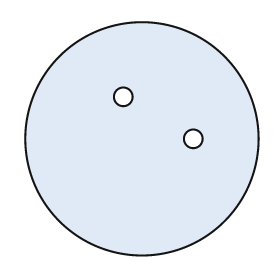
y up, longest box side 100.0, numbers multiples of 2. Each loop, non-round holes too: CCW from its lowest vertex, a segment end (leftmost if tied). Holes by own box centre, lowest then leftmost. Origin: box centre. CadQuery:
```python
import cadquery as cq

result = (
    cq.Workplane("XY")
    .moveTo(0.0, 0.0)
    .circle(50.0)
    .moveTo(22.0, 0.0)
    .circle(4.0)
    .moveTo(-8.0, 18.0)
    .circle(4.0)
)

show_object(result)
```